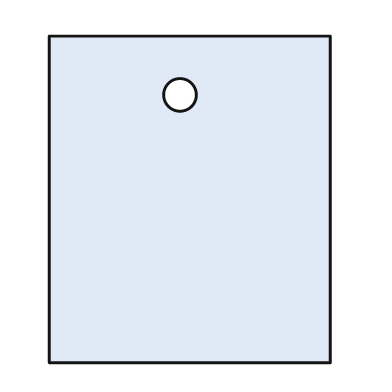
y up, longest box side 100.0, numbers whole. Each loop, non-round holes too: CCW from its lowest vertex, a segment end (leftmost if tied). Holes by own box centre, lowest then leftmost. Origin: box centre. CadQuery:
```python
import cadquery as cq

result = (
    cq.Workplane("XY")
    .moveTo(-43.0, -50.0)
    .lineTo(43.0, -50.0)
    .lineTo(43.0, 50.0)
    .lineTo(-43.0, 50.0)
    .close()
    .moveTo(-3.0, 32.0)
    .circle(5.0)
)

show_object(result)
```